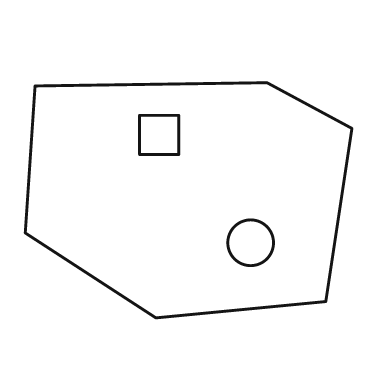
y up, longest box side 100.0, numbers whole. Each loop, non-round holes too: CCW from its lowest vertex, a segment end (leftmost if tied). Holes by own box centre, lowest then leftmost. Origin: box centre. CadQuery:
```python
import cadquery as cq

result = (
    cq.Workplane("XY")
    .moveTo(-10.0, -36.0)
    .lineTo(42.0, -31.0)
    .lineTo(50.0, 22.0)
    .lineTo(24.0, 36.0)
    .lineTo(-47.0, 35.0)
    .lineTo(-50.0, -10.0)
    .close()
    .moveTo(19.0, -13.0)
    .circle(7.0)
    .moveTo(-15.0, 14.0)
    .lineTo(-3.0, 14.0)
    .lineTo(-3.0, 26.0)
    .lineTo(-15.0, 26.0)
    .close()
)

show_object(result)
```